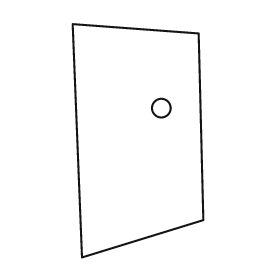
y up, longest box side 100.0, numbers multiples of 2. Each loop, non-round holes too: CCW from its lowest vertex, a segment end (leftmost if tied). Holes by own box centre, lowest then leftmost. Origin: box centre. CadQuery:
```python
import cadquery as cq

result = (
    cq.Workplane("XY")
    .moveTo(-24.0, -50.0)
    .lineTo(28.0, -34.0)
    .lineTo(26.0, 46.0)
    .lineTo(-28.0, 50.0)
    .close()
    .moveTo(10.0, 14.0)
    .circle(4.0)
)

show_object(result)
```